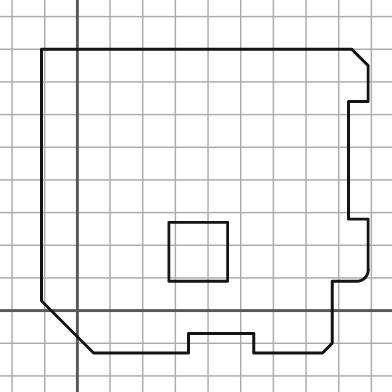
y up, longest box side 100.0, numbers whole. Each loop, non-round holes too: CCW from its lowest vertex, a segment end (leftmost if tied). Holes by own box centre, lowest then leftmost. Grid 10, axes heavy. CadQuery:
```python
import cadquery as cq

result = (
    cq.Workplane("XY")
    .moveTo(5.0, -13.0)
    .lineTo(34.0, -13.0)
    .lineTo(34.0, -7.0)
    .lineTo(54.0, -7.0)
    .lineTo(54.0, -13.0)
    .lineTo(75.0, -13.0)
    .lineTo(78.0, -10.0)
    .lineTo(78.0, 9.0)
    .lineTo(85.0, 9.0)
    .threePointArc((88.0, 10.0), (89.0, 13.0))
    .lineTo(89.0, 28.0)
    .lineTo(83.0, 28.0)
    .lineTo(83.0, 64.0)
    .lineTo(89.0, 64.0)
    .lineTo(89.0, 75.0)
    .lineTo(84.0, 80.0)
    .lineTo(-11.0, 80.0)
    .lineTo(-11.0, 3.0)
    .close()
    .moveTo(28.0, 9.0)
    .lineTo(46.0, 9.0)
    .lineTo(46.0, 27.0)
    .lineTo(28.0, 27.0)
    .close()
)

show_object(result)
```